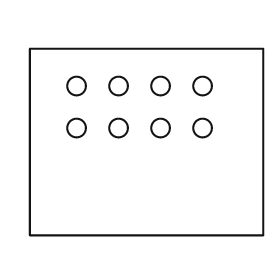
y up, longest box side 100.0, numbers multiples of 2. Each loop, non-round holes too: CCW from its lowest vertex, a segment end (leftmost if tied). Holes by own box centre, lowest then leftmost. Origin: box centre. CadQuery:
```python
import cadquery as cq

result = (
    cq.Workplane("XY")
    .moveTo(-50.0, -40.0)
    .lineTo(50.0, -40.0)
    .lineTo(50.0, 40.0)
    .lineTo(-50.0, 40.0)
    .close()
    .moveTo(-30.0, 6.0)
    .circle(4.0)
    .moveTo(-12.0, 6.0)
    .circle(4.0)
    .moveTo(6.0, 6.0)
    .circle(4.0)
    .moveTo(24.0, 6.0)
    .circle(4.0)
    .moveTo(-30.0, 24.0)
    .circle(4.0)
    .moveTo(-12.0, 24.0)
    .circle(4.0)
    .moveTo(6.0, 24.0)
    .circle(4.0)
    .moveTo(24.0, 24.0)
    .circle(4.0)
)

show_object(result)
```